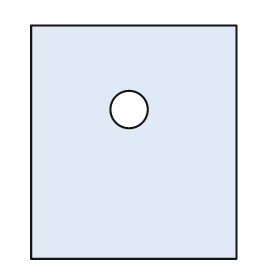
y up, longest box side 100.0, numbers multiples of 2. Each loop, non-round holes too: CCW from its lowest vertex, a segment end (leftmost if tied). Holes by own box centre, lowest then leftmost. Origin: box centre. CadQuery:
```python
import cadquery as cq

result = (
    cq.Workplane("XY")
    .moveTo(-44.0, -50.0)
    .lineTo(44.0, -50.0)
    .lineTo(44.0, 50.0)
    .lineTo(-44.0, 50.0)
    .close()
    .moveTo(-2.0, 14.0)
    .circle(8.0)
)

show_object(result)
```